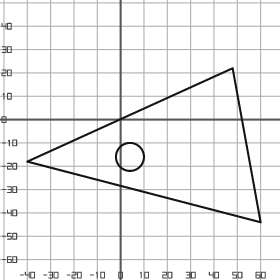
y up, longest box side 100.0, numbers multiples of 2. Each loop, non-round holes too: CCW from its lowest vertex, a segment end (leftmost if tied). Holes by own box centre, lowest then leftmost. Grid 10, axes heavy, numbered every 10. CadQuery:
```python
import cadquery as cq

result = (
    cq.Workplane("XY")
    .moveTo(60.0, -44.0)
    .lineTo(48.0, 22.0)
    .lineTo(-40.0, -18.0)
    .close()
    .moveTo(4.0, -16.0)
    .circle(6.0)
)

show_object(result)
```